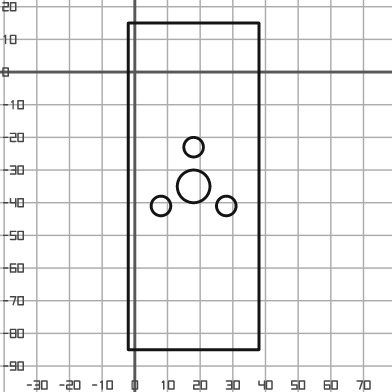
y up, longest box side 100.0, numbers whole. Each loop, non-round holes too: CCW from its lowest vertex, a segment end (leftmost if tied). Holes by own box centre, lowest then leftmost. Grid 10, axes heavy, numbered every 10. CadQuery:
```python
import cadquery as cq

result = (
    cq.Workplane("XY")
    .moveTo(-2.0, -85.0)
    .lineTo(38.0, -85.0)
    .lineTo(38.0, 15.0)
    .lineTo(-2.0, 15.0)
    .close()
    .moveTo(8.0, -41.0)
    .circle(3.0)
    .moveTo(28.0, -41.0)
    .circle(3.0)
    .moveTo(18.0, -35.0)
    .circle(5.0)
    .moveTo(18.0, -23.0)
    .circle(3.0)
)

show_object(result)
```